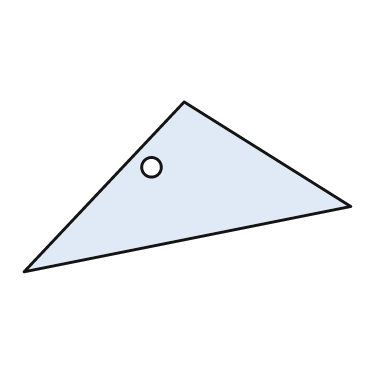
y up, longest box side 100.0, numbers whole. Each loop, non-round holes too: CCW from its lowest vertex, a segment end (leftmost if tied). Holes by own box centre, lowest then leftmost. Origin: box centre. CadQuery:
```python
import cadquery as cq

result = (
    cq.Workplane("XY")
    .moveTo(-50.0, -26.0)
    .lineTo(50.0, -6.0)
    .lineTo(-1.0, 26.0)
    .close()
    .moveTo(-11.0, 6.0)
    .circle(3.0)
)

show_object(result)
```